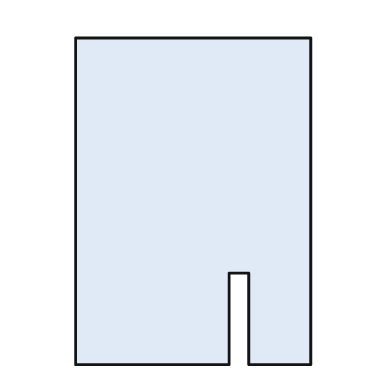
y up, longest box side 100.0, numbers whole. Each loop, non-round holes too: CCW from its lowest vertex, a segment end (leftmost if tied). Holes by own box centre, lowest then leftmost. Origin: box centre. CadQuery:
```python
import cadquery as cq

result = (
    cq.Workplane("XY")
    .moveTo(-36.0, -50.0)
    .lineTo(11.0, -50.0)
    .lineTo(11.0, -22.0)
    .lineTo(17.0, -22.0)
    .lineTo(17.0, -50.0)
    .lineTo(36.0, -50.0)
    .lineTo(36.0, 50.0)
    .lineTo(-36.0, 50.0)
    .close()
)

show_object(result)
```